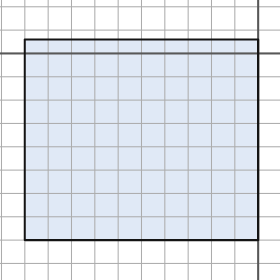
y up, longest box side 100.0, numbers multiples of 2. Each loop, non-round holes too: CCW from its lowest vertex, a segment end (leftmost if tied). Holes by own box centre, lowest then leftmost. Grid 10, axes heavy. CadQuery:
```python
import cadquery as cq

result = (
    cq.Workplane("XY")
    .moveTo(-100.0, -80.0)
    .lineTo(0.0, -80.0)
    .lineTo(0.0, 6.0)
    .lineTo(-100.0, 6.0)
    .close()
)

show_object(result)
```